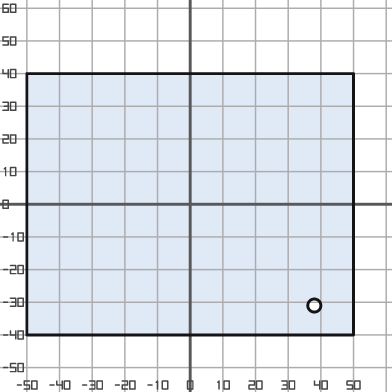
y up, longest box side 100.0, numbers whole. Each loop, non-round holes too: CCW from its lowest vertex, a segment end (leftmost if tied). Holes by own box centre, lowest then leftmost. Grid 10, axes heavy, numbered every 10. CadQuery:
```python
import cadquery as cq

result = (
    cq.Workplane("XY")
    .moveTo(-50.0, -40.0)
    .lineTo(50.0, -40.0)
    .lineTo(50.0, 40.0)
    .lineTo(-50.0, 40.0)
    .close()
    .moveTo(38.0, -31.0)
    .circle(2.0)
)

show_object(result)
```